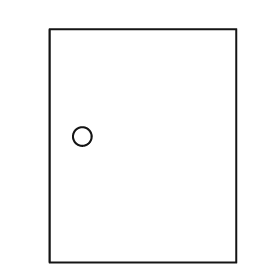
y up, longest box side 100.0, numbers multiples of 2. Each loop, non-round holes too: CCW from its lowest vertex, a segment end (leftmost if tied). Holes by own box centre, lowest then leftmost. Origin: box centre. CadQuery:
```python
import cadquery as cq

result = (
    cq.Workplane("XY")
    .moveTo(-40.0, -50.0)
    .lineTo(40.0, -50.0)
    .lineTo(40.0, 50.0)
    .lineTo(-40.0, 50.0)
    .close()
    .moveTo(-26.0, 4.0)
    .circle(4.0)
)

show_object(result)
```